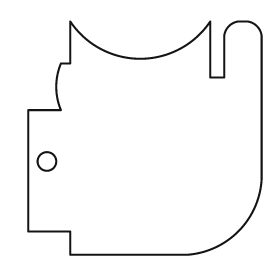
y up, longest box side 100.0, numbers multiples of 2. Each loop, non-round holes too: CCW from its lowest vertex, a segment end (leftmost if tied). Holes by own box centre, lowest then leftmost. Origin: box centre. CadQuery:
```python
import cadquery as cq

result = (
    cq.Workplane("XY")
    .moveTo(-32.0, -50.0)
    .lineTo(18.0, -50.0)
    .threePointArc((40.0, -40.0), (50.0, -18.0))
    .lineTo(50.0, 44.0)
    .threePointArc((48.0, 48.0), (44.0, 50.0))
    .lineTo(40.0, 50.0)
    .threePointArc((36.0, 48.0), (34.0, 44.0))
    .lineTo(34.0, 26.0)
    .lineTo(28.0, 26.0)
    .lineTo(28.0, 50.0)
    .threePointArc((-2.0, 34.0), (-32.0, 50.0))
    .lineTo(-32.0, 32.0)
    .lineTo(-36.0, 32.0)
    .threePointArc((-38.0, 22.0), (-36.0, 12.0))
    .lineTo(-50.0, 12.0)
    .lineTo(-50.0, -40.0)
    .lineTo(-32.0, -40.0)
    .close()
    .moveTo(-42.0, -10.0)
    .circle(4.0)
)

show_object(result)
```